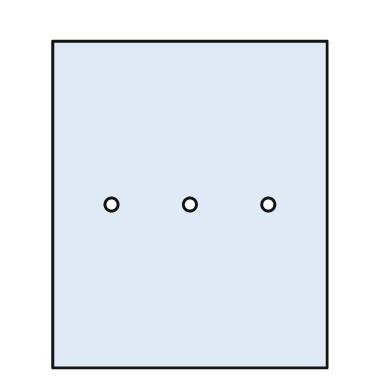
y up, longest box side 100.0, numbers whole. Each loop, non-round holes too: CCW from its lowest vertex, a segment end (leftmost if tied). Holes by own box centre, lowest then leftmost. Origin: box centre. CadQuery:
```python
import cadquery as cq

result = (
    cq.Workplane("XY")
    .moveTo(-42.0, -50.0)
    .lineTo(42.0, -50.0)
    .lineTo(42.0, 50.0)
    .lineTo(-42.0, 50.0)
    .close()
    .moveTo(-24.0, 0.0)
    .circle(2.0)
    .moveTo(0.0, 0.0)
    .circle(2.0)
    .moveTo(24.0, 0.0)
    .circle(2.0)
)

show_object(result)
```